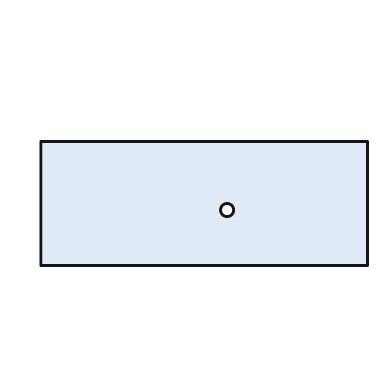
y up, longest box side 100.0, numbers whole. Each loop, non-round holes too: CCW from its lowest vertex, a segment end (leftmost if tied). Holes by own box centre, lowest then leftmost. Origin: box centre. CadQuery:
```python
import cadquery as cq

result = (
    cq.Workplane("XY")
    .moveTo(-50.0, -19.0)
    .lineTo(50.0, -19.0)
    .lineTo(50.0, 19.0)
    .lineTo(-50.0, 19.0)
    .close()
    .moveTo(7.0, -2.0)
    .circle(2.0)
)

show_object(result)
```